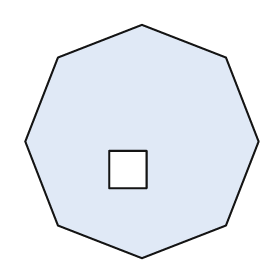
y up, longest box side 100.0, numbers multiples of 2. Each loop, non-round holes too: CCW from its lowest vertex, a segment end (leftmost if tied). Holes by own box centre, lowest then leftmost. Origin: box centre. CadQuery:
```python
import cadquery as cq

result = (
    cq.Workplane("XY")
    .moveTo(0.0, -50.0)
    .lineTo(36.0, -36.0)
    .lineTo(50.0, 0.0)
    .lineTo(36.0, 36.0)
    .lineTo(0.0, 50.0)
    .lineTo(-36.0, 36.0)
    .lineTo(-50.0, 0.0)
    .lineTo(-36.0, -36.0)
    .close()
    .moveTo(-14.0, -20.0)
    .lineTo(2.0, -20.0)
    .lineTo(2.0, -4.0)
    .lineTo(-14.0, -4.0)
    .close()
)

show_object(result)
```